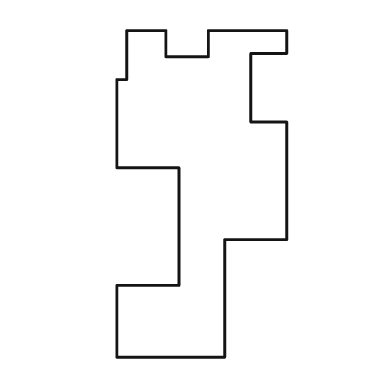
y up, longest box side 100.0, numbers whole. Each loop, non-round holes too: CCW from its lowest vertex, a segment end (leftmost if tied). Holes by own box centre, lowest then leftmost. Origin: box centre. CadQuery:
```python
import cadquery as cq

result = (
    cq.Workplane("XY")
    .moveTo(-26.0, -50.0)
    .lineTo(7.0, -50.0)
    .lineTo(7.0, -14.0)
    .lineTo(26.0, -14.0)
    .lineTo(26.0, 22.0)
    .lineTo(15.0, 22.0)
    .lineTo(15.0, 43.0)
    .lineTo(26.0, 43.0)
    .lineTo(26.0, 50.0)
    .lineTo(2.0, 50.0)
    .lineTo(2.0, 42.0)
    .lineTo(-11.0, 42.0)
    .lineTo(-11.0, 50.0)
    .lineTo(-23.0, 50.0)
    .lineTo(-23.0, 35.0)
    .lineTo(-26.0, 35.0)
    .lineTo(-26.0, 8.0)
    .lineTo(-7.0, 8.0)
    .lineTo(-7.0, -28.0)
    .lineTo(-26.0, -28.0)
    .close()
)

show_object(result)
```